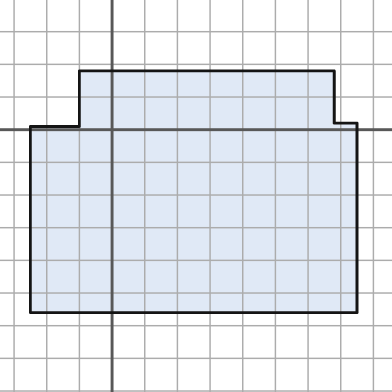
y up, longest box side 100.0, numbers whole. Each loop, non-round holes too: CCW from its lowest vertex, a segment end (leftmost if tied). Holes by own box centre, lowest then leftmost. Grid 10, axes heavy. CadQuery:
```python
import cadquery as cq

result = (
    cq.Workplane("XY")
    .moveTo(-25.0, -56.0)
    .lineTo(75.0, -56.0)
    .lineTo(75.0, 2.0)
    .lineTo(68.0, 2.0)
    .lineTo(68.0, 18.0)
    .lineTo(-10.0, 18.0)
    .lineTo(-10.0, 1.0)
    .lineTo(-25.0, 1.0)
    .close()
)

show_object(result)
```